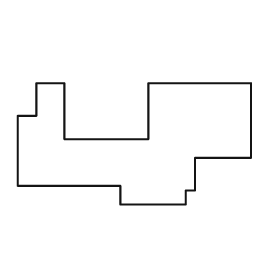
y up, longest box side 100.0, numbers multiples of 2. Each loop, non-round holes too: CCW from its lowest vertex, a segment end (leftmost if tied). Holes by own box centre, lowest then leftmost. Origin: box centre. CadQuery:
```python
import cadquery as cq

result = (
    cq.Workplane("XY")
    .moveTo(-6.0, -26.0)
    .lineTo(22.0, -26.0)
    .lineTo(22.0, -20.0)
    .lineTo(26.0, -20.0)
    .lineTo(26.0, -6.0)
    .lineTo(50.0, -6.0)
    .lineTo(50.0, 26.0)
    .lineTo(6.0, 26.0)
    .lineTo(6.0, 2.0)
    .lineTo(-30.0, 2.0)
    .lineTo(-30.0, 26.0)
    .lineTo(-42.0, 26.0)
    .lineTo(-42.0, 12.0)
    .lineTo(-50.0, 12.0)
    .lineTo(-50.0, -18.0)
    .lineTo(-6.0, -18.0)
    .close()
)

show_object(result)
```